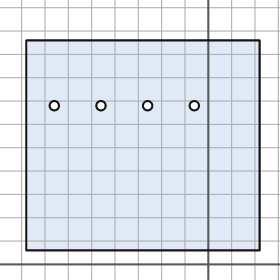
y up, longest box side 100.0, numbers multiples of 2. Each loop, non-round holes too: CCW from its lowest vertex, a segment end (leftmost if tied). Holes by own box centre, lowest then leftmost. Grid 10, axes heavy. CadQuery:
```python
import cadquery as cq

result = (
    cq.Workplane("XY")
    .moveTo(-78.0, 6.0)
    .lineTo(22.0, 6.0)
    .lineTo(22.0, 96.0)
    .lineTo(-78.0, 96.0)
    .close()
    .moveTo(-66.0, 68.0)
    .circle(2.0)
    .moveTo(-46.0, 68.0)
    .circle(2.0)
    .moveTo(-26.0, 68.0)
    .circle(2.0)
    .moveTo(-6.0, 68.0)
    .circle(2.0)
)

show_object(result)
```